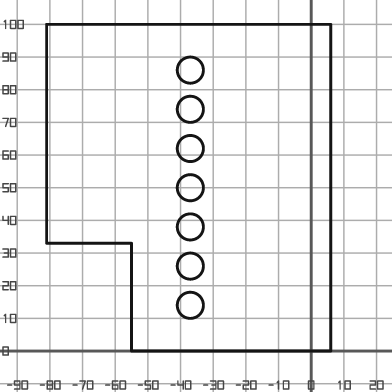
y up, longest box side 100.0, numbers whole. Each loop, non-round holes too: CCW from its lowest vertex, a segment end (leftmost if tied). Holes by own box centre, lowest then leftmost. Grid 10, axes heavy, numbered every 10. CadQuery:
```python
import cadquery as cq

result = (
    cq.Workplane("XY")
    .moveTo(-55.0, 0.0)
    .lineTo(6.0, 0.0)
    .lineTo(6.0, 100.0)
    .lineTo(-81.0, 100.0)
    .lineTo(-81.0, 33.0)
    .lineTo(-55.0, 33.0)
    .close()
    .moveTo(-37.0, 14.0)
    .circle(4.0)
    .moveTo(-37.0, 26.0)
    .circle(4.0)
    .moveTo(-37.0, 38.0)
    .circle(4.0)
    .moveTo(-37.0, 50.0)
    .circle(4.0)
    .moveTo(-37.0, 62.0)
    .circle(4.0)
    .moveTo(-37.0, 74.0)
    .circle(4.0)
    .moveTo(-37.0, 86.0)
    .circle(4.0)
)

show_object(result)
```